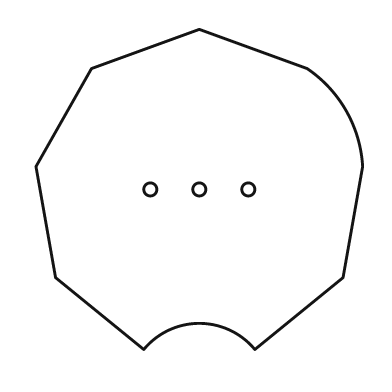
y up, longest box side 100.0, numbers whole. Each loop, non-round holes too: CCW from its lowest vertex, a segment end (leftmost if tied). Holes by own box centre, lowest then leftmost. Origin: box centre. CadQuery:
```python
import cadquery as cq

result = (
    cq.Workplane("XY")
    .moveTo(-17.0, -49.0)
    .threePointArc((0.0, -41.0), (17.0, -49.0))
    .lineTo(44.0, -27.0)
    .lineTo(50.0, 7.0)
    .threePointArc((45.0, 24.0), (33.0, 37.0))
    .lineTo(0.0, 49.0)
    .lineTo(-33.0, 37.0)
    .lineTo(-50.0, 7.0)
    .lineTo(-44.0, -27.0)
    .close()
    .moveTo(-15.0, 0.0)
    .circle(2.0)
    .moveTo(0.0, 0.0)
    .circle(2.0)
    .moveTo(15.0, 0.0)
    .circle(2.0)
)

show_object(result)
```